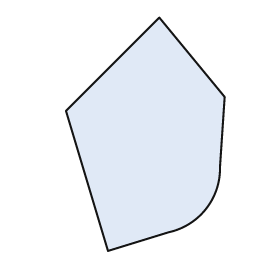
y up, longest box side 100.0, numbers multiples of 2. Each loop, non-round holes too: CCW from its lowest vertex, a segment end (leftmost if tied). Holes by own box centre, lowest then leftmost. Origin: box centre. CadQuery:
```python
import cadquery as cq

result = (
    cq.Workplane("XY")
    .moveTo(-16.0, -50.0)
    .lineTo(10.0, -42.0)
    .threePointArc((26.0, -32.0), (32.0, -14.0))
    .lineTo(34.0, 16.0)
    .lineTo(6.0, 50.0)
    .lineTo(-34.0, 10.0)
    .close()
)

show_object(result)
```